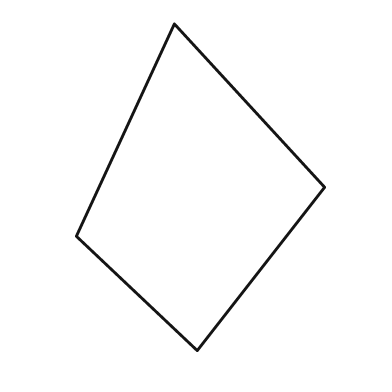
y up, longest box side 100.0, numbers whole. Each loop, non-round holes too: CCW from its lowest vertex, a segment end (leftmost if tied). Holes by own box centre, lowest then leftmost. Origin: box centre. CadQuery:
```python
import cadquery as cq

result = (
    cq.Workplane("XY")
    .moveTo(-1.0, -50.0)
    .lineTo(38.0, 0.0)
    .lineTo(-8.0, 50.0)
    .lineTo(-38.0, -15.0)
    .close()
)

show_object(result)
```